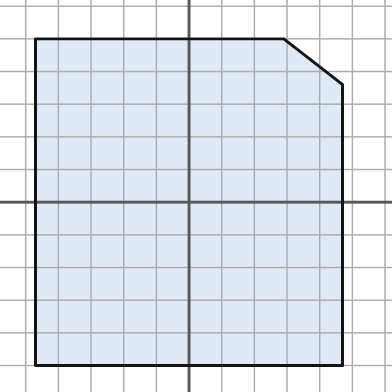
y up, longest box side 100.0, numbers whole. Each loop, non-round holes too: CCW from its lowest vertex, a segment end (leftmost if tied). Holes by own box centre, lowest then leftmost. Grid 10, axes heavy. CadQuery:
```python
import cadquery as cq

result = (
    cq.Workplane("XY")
    .moveTo(-47.0, -50.0)
    .lineTo(47.0, -50.0)
    .lineTo(47.0, 36.0)
    .lineTo(29.0, 50.0)
    .lineTo(-47.0, 50.0)
    .close()
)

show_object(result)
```